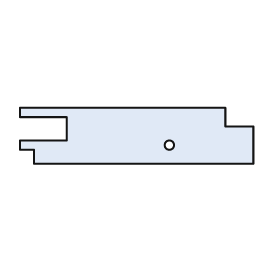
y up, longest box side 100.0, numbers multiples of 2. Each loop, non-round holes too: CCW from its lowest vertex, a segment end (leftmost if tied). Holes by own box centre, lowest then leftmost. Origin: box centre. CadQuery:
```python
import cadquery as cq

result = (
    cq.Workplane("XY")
    .moveTo(-44.0, -12.0)
    .lineTo(50.0, -12.0)
    .lineTo(50.0, 4.0)
    .lineTo(38.0, 4.0)
    .lineTo(38.0, 12.0)
    .lineTo(-50.0, 12.0)
    .lineTo(-50.0, 8.0)
    .lineTo(-30.0, 8.0)
    .lineTo(-30.0, -2.0)
    .lineTo(-50.0, -2.0)
    .lineTo(-50.0, -6.0)
    .lineTo(-44.0, -6.0)
    .close()
    .moveTo(14.0, -4.0)
    .circle(2.0)
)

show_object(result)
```